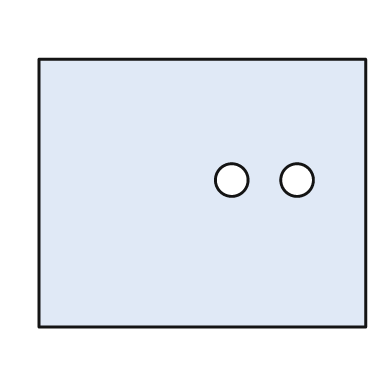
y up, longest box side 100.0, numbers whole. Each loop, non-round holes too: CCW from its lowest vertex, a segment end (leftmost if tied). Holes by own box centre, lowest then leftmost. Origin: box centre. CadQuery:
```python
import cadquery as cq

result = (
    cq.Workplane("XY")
    .moveTo(-50.0, -41.0)
    .lineTo(50.0, -41.0)
    .lineTo(50.0, 41.0)
    .lineTo(-50.0, 41.0)
    .close()
    .moveTo(9.0, 4.0)
    .circle(5.0)
    .moveTo(29.0, 4.0)
    .circle(5.0)
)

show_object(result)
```